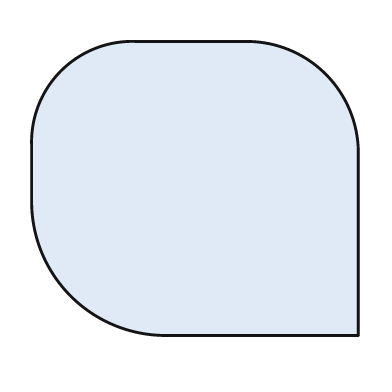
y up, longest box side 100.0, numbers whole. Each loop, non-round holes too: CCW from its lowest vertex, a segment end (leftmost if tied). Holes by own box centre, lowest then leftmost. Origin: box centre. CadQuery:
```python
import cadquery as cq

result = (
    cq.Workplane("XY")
    .moveTo(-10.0, -45.0)
    .lineTo(50.0, -45.0)
    .lineTo(50.0, 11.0)
    .threePointArc((40.0, 35.0), (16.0, 45.0))
    .lineTo(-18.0, 45.0)
    .threePointArc((-41.0, 36.0), (-50.0, 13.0))
    .lineTo(-50.0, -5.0)
    .threePointArc((-38.0, -33.0), (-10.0, -45.0))
    .close()
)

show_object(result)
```